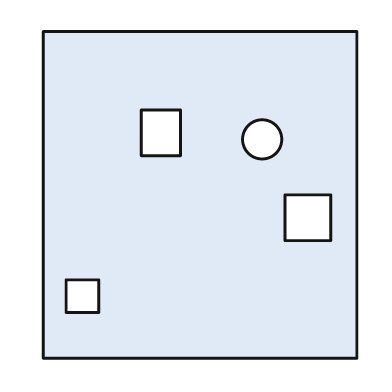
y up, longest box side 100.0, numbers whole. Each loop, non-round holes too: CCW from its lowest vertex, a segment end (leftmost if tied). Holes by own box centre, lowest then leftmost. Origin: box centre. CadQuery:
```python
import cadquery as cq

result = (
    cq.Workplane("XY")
    .moveTo(-48.0, -50.0)
    .lineTo(48.0, -50.0)
    .lineTo(48.0, 50.0)
    .lineTo(-48.0, 50.0)
    .close()
    .moveTo(-41.0, -36.0)
    .lineTo(-31.0, -36.0)
    .lineTo(-31.0, -26.0)
    .lineTo(-41.0, -26.0)
    .close()
    .moveTo(26.0, -14.0)
    .lineTo(40.0, -14.0)
    .lineTo(40.0, 0.0)
    .lineTo(26.0, 0.0)
    .close()
    .moveTo(19.0, 17.0)
    .circle(6.0)
    .moveTo(-18.0, 12.0)
    .lineTo(-6.0, 12.0)
    .lineTo(-6.0, 26.0)
    .lineTo(-18.0, 26.0)
    .close()
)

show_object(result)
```